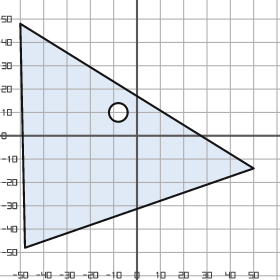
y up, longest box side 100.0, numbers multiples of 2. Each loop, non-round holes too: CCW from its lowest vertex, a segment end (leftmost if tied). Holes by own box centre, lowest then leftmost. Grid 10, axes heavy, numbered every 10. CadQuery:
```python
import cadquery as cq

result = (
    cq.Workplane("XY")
    .moveTo(-48.0, -48.0)
    .lineTo(50.0, -14.0)
    .lineTo(-50.0, 48.0)
    .close()
    .moveTo(-8.0, 10.0)
    .circle(4.0)
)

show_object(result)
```